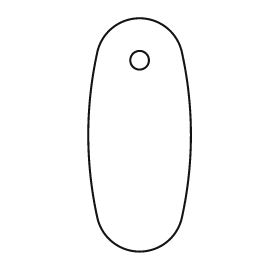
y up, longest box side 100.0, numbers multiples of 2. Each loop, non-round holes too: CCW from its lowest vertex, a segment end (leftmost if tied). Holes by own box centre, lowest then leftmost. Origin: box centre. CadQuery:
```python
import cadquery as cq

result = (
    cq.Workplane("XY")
    .moveTo(-18.0, -36.0)
    .threePointArc((0.0, -50.0), (18.0, -36.0))
    .threePointArc((22.0, 0.0), (18.0, 36.0))
    .threePointArc((0.0, 50.0), (-18.0, 36.0))
    .threePointArc((-22.0, 0.0), (-18.0, -36.0))
    .close()
    .moveTo(0.0, 32.0)
    .circle(4.0)
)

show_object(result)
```